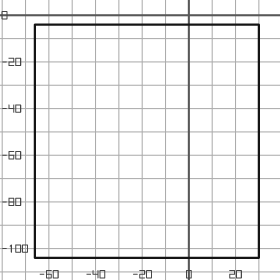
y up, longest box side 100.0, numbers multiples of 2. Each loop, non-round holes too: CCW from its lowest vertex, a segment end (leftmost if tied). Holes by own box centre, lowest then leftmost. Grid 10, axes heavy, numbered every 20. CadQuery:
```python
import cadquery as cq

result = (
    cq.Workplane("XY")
    .moveTo(-66.0, -104.0)
    .lineTo(30.0, -104.0)
    .lineTo(30.0, -4.0)
    .lineTo(-66.0, -4.0)
    .close()
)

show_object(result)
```